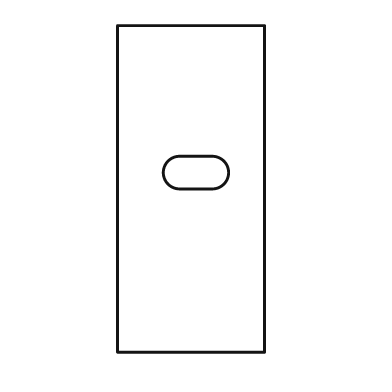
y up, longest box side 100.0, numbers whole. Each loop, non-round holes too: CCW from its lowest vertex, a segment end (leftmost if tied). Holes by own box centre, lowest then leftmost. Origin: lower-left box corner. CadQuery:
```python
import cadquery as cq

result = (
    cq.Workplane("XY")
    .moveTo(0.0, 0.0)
    .lineTo(45.0, 0.0)
    .lineTo(45.0, 100.0)
    .lineTo(0.0, 100.0)
    .close()
    .moveTo(19.0, 50.0)
    .lineTo(29.0, 50.0)
    .threePointArc((34.0, 55.0), (29.0, 60.0))
    .lineTo(19.0, 60.0)
    .threePointArc((14.0, 55.0), (19.0, 50.0))
    .close()
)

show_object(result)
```